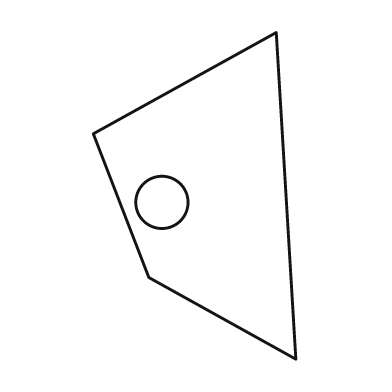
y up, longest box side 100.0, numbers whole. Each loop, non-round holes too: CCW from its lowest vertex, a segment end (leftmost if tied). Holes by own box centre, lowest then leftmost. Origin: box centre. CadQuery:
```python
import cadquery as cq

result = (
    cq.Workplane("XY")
    .moveTo(31.0, -50.0)
    .lineTo(25.0, 50.0)
    .lineTo(-31.0, 19.0)
    .lineTo(-14.0, -25.0)
    .close()
    .moveTo(-10.0, -2.0)
    .circle(8.0)
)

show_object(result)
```